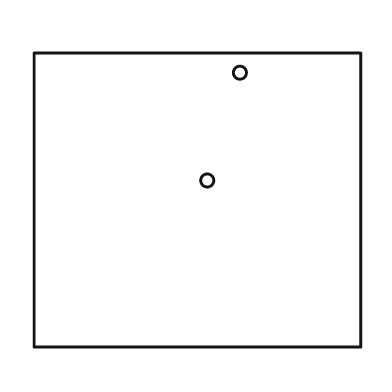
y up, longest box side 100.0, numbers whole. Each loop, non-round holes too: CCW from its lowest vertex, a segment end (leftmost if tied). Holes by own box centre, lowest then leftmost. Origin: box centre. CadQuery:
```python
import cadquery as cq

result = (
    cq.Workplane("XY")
    .moveTo(-50.0, -45.0)
    .lineTo(50.0, -45.0)
    .lineTo(50.0, 45.0)
    .lineTo(-50.0, 45.0)
    .close()
    .moveTo(3.0, 6.0)
    .circle(2.0)
    .moveTo(13.0, 39.0)
    .circle(2.0)
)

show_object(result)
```